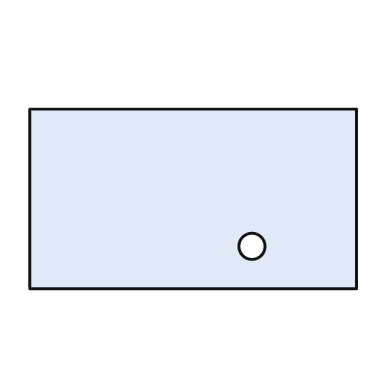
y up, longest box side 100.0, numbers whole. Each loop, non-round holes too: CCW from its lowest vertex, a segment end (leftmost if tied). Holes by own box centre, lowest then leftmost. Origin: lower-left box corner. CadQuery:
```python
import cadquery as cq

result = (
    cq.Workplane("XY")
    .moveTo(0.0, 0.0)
    .lineTo(100.0, 0.0)
    .lineTo(100.0, 55.0)
    .lineTo(0.0, 55.0)
    .close()
    .moveTo(68.0, 13.0)
    .circle(4.0)
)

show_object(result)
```